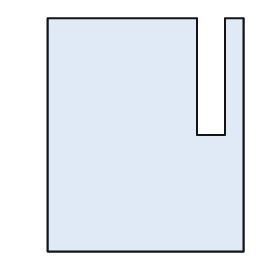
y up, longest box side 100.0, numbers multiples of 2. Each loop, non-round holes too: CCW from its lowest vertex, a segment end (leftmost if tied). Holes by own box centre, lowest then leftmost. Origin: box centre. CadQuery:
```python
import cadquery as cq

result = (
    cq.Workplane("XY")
    .moveTo(-42.0, -50.0)
    .lineTo(42.0, -50.0)
    .lineTo(42.0, 50.0)
    .lineTo(34.0, 50.0)
    .lineTo(34.0, 0.0)
    .lineTo(22.0, 0.0)
    .lineTo(22.0, 50.0)
    .lineTo(-42.0, 50.0)
    .close()
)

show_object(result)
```